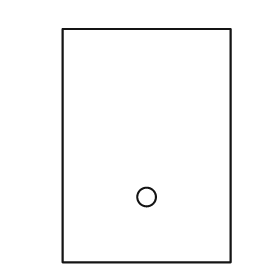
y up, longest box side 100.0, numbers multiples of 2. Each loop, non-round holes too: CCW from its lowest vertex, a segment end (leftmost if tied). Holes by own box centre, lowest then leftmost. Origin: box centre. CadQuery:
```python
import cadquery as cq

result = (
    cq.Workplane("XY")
    .moveTo(-36.0, -50.0)
    .lineTo(36.0, -50.0)
    .lineTo(36.0, 50.0)
    .lineTo(-36.0, 50.0)
    .close()
    .moveTo(0.0, -22.0)
    .circle(4.0)
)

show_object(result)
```